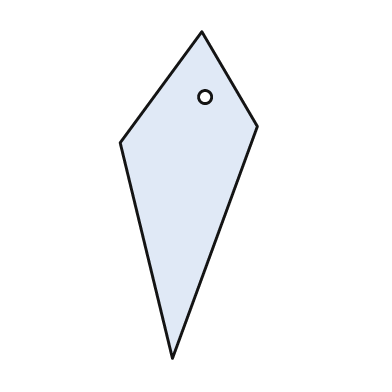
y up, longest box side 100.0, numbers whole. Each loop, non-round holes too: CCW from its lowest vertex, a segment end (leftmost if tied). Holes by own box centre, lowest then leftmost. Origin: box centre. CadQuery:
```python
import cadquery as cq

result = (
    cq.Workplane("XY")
    .moveTo(-5.0, -50.0)
    .lineTo(21.0, 21.0)
    .lineTo(4.0, 50.0)
    .lineTo(-21.0, 16.0)
    .close()
    .moveTo(5.0, 30.0)
    .circle(2.0)
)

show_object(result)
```